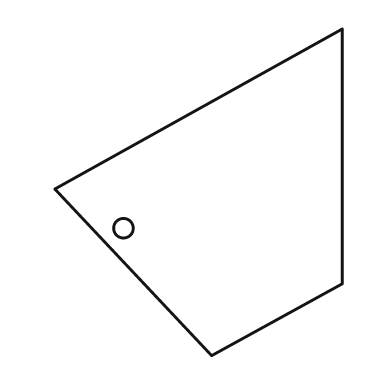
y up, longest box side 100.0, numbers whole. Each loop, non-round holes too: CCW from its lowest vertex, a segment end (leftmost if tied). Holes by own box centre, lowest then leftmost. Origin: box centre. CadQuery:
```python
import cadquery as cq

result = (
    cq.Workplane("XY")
    .moveTo(4.0, -50.0)
    .lineTo(44.0, -28.0)
    .lineTo(44.0, 50.0)
    .lineTo(-44.0, 1.0)
    .close()
    .moveTo(-23.0, -11.0)
    .circle(3.0)
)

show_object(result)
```